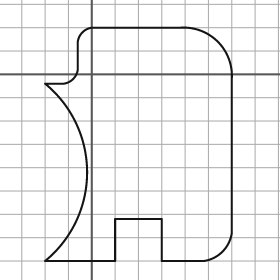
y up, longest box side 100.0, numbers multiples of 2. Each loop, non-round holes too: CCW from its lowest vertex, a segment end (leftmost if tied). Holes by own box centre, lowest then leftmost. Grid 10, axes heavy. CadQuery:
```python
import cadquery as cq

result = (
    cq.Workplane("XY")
    .moveTo(-20.0, -80.0)
    .lineTo(10.0, -80.0)
    .lineTo(10.0, -62.0)
    .lineTo(30.0, -62.0)
    .lineTo(30.0, -80.0)
    .lineTo(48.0, -80.0)
    .threePointArc((56.0, -76.0), (60.0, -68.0))
    .lineTo(60.0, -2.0)
    .threePointArc((54.0, 14.0), (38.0, 20.0))
    .lineTo(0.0, 20.0)
    .threePointArc((-4.0, 18.0), (-6.0, 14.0))
    .lineTo(-6.0, 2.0)
    .threePointArc((-8.0, -2.0), (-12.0, -4.0))
    .lineTo(-20.0, -4.0)
    .threePointArc((-2.0, -42.0), (-20.0, -80.0))
    .close()
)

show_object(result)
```